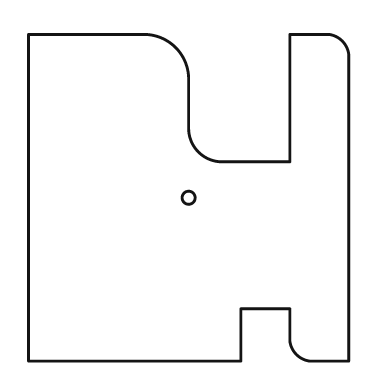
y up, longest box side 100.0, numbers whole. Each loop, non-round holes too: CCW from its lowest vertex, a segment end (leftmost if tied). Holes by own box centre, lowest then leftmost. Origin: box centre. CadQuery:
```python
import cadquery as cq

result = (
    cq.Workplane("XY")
    .moveTo(-49.0, -50.0)
    .lineTo(16.0, -50.0)
    .lineTo(16.0, -34.0)
    .lineTo(31.0, -34.0)
    .lineTo(31.0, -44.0)
    .threePointArc((33.0, -48.0), (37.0, -50.0))
    .lineTo(49.0, -50.0)
    .lineTo(49.0, 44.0)
    .threePointArc((47.0, 48.0), (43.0, 50.0))
    .lineTo(31.0, 50.0)
    .lineTo(31.0, 11.0)
    .lineTo(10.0, 11.0)
    .threePointArc((3.0, 14.0), (0.0, 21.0))
    .lineTo(0.0, 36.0)
    .threePointArc((-4.0, 46.0), (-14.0, 50.0))
    .lineTo(-49.0, 50.0)
    .close()
    .moveTo(0.0, 0.0)
    .circle(2.0)
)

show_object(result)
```